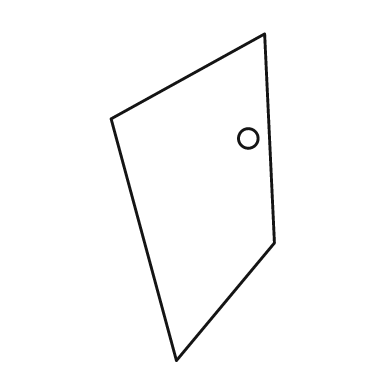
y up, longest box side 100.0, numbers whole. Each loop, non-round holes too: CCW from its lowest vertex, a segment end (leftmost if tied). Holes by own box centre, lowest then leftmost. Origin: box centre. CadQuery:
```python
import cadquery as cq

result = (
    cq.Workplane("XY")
    .moveTo(-5.0, -50.0)
    .lineTo(25.0, -14.0)
    .lineTo(22.0, 50.0)
    .lineTo(-25.0, 24.0)
    .close()
    .moveTo(17.0, 18.0)
    .circle(3.0)
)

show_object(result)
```